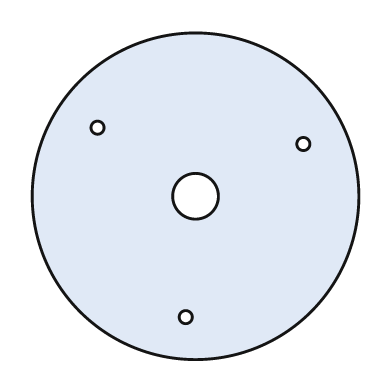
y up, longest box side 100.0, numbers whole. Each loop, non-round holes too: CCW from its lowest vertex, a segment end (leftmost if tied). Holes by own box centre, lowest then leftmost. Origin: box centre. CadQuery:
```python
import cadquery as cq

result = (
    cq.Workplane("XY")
    .moveTo(0.0, 0.0)
    .circle(50.0)
    .moveTo(-3.0, -37.0)
    .circle(2.0)
    .moveTo(0.0, 0.0)
    .circle(7.0)
    .moveTo(33.0, 16.0)
    .circle(2.0)
    .moveTo(-30.0, 21.0)
    .circle(2.0)
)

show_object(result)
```